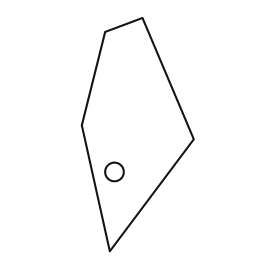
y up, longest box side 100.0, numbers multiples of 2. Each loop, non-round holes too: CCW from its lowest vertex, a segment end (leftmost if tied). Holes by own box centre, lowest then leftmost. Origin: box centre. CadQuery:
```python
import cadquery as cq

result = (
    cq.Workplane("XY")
    .moveTo(-12.0, -50.0)
    .lineTo(24.0, -2.0)
    .lineTo(2.0, 50.0)
    .lineTo(-14.0, 44.0)
    .lineTo(-24.0, 4.0)
    .close()
    .moveTo(-10.0, -16.0)
    .circle(4.0)
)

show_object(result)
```